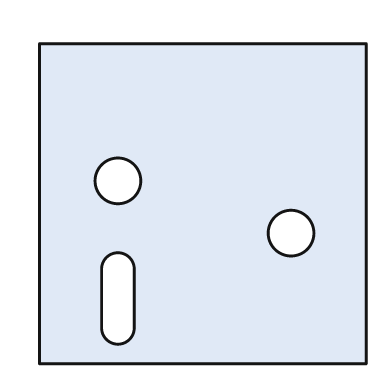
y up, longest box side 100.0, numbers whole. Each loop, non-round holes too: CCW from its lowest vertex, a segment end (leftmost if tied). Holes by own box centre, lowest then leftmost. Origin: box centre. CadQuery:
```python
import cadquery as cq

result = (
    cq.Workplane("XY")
    .moveTo(-50.0, -49.0)
    .lineTo(50.0, -49.0)
    .lineTo(50.0, 49.0)
    .lineTo(-50.0, 49.0)
    .close()
    .moveTo(-31.0, -38.0)
    .threePointArc((-26.0, -43.0), (-21.0, -38.0))
    .lineTo(-21.0, -20.0)
    .threePointArc((-26.0, -15.0), (-31.0, -20.0))
    .close()
    .moveTo(27.0, -9.0)
    .circle(7.0)
    .moveTo(-26.0, 7.0)
    .circle(7.0)
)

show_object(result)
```